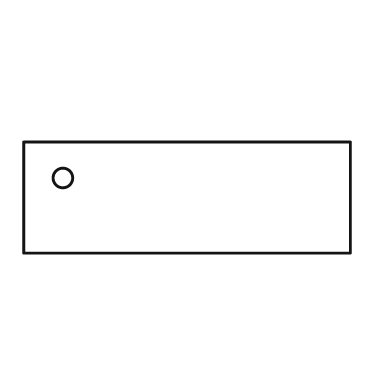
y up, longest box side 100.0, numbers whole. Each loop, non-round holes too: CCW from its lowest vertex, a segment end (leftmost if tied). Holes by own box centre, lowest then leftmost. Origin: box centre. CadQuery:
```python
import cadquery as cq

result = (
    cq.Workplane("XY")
    .moveTo(-50.0, -17.0)
    .lineTo(50.0, -17.0)
    .lineTo(50.0, 17.0)
    .lineTo(-50.0, 17.0)
    .close()
    .moveTo(-38.0, 6.0)
    .circle(3.0)
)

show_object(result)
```